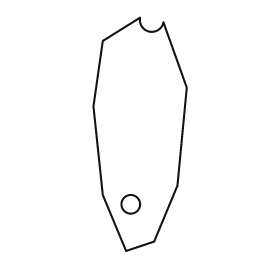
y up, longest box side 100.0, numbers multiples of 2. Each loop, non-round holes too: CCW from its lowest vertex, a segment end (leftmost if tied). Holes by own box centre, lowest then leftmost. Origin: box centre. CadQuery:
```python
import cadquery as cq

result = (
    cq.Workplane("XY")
    .moveTo(-6.0, -50.0)
    .lineTo(6.0, -46.0)
    .lineTo(16.0, -22.0)
    .lineTo(20.0, 20.0)
    .lineTo(10.0, 48.0)
    .threePointArc((4.0, 44.0), (0.0, 50.0))
    .lineTo(-16.0, 40.0)
    .lineTo(-20.0, 12.0)
    .lineTo(-16.0, -26.0)
    .close()
    .moveTo(-4.0, -30.0)
    .circle(4.0)
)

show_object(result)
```